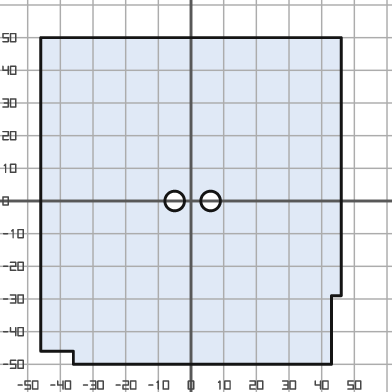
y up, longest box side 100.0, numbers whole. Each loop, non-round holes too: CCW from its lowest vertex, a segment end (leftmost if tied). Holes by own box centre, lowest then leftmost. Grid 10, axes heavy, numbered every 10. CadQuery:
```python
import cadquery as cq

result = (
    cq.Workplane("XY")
    .moveTo(-36.0, -50.0)
    .lineTo(43.0, -50.0)
    .lineTo(43.0, -29.0)
    .lineTo(46.0, -29.0)
    .lineTo(46.0, 50.0)
    .lineTo(-46.0, 50.0)
    .lineTo(-46.0, -46.0)
    .lineTo(-36.0, -46.0)
    .close()
    .moveTo(-5.0, 0.0)
    .circle(3.0)
    .moveTo(6.0, 0.0)
    .circle(3.0)
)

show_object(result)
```